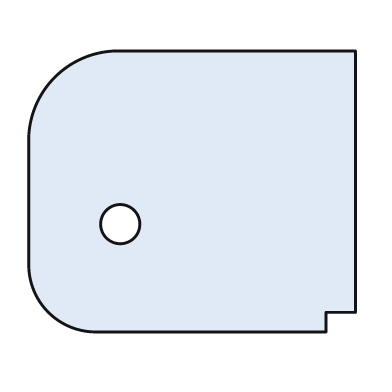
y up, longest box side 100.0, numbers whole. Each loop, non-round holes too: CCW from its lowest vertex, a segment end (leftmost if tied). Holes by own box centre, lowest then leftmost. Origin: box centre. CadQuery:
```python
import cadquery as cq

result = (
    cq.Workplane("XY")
    .moveTo(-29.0, -43.0)
    .lineTo(41.0, -43.0)
    .lineTo(41.0, -37.0)
    .lineTo(50.0, -37.0)
    .lineTo(50.0, 43.0)
    .lineTo(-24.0, 43.0)
    .threePointArc((-42.0, 35.0), (-50.0, 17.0))
    .lineTo(-50.0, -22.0)
    .threePointArc((-44.0, -37.0), (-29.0, -43.0))
    .close()
    .moveTo(-22.0, -10.0)
    .circle(6.0)
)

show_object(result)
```